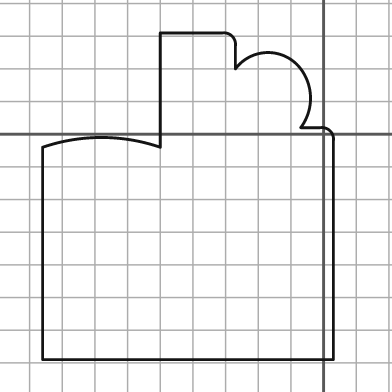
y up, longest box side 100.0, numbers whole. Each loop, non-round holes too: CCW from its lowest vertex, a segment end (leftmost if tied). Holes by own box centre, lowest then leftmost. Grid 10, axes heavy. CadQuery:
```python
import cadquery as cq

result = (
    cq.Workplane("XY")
    .moveTo(-86.0, -69.0)
    .lineTo(3.0, -69.0)
    .lineTo(3.0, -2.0)
    .threePointArc((2.0, 1.0), (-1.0, 2.0))
    .lineTo(-7.0, 2.0)
    .threePointArc((-4.0, 11.0), (-7.0, 20.0))
    .threePointArc((-17.0, 25.0), (-27.0, 20.0))
    .lineTo(-27.0, 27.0)
    .threePointArc((-28.0, 30.0), (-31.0, 31.0))
    .lineTo(-50.0, 31.0)
    .lineTo(-50.0, -4.0)
    .threePointArc((-68.0, -1.0), (-86.0, -4.0))
    .close()
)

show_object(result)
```